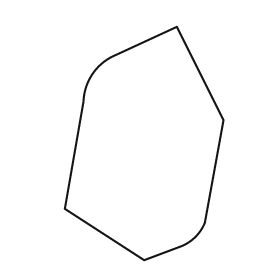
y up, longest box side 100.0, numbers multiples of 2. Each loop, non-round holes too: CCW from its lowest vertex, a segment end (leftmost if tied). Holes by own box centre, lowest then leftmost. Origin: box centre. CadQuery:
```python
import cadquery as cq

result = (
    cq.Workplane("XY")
    .moveTo(0.0, -50.0)
    .lineTo(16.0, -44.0)
    .threePointArc((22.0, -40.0), (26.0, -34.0))
    .lineTo(34.0, 10.0)
    .lineTo(14.0, 50.0)
    .lineTo(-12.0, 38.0)
    .threePointArc((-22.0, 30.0), (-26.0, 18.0))
    .lineTo(-34.0, -28.0)
    .close()
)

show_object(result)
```